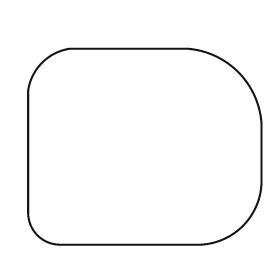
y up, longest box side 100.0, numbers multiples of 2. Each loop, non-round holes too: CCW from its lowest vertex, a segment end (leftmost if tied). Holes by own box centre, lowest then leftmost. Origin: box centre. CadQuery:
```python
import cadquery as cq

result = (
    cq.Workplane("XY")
    .moveTo(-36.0, -42.0)
    .lineTo(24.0, -42.0)
    .threePointArc((42.0, -34.0), (50.0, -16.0))
    .lineTo(50.0, 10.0)
    .threePointArc((40.0, 32.0), (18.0, 42.0))
    .lineTo(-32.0, 42.0)
    .threePointArc((-44.0, 36.0), (-50.0, 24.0))
    .lineTo(-50.0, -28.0)
    .threePointArc((-46.0, -38.0), (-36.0, -42.0))
    .close()
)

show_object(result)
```